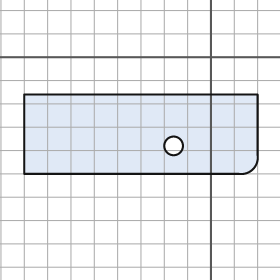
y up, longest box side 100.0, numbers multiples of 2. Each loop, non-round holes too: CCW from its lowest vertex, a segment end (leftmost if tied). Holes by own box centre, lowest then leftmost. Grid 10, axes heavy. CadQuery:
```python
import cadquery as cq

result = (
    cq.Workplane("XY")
    .moveTo(-80.0, -50.0)
    .lineTo(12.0, -50.0)
    .threePointArc((18.0, -48.0), (20.0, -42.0))
    .lineTo(20.0, -16.0)
    .lineTo(-80.0, -16.0)
    .close()
    .moveTo(-16.0, -38.0)
    .circle(4.0)
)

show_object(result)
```